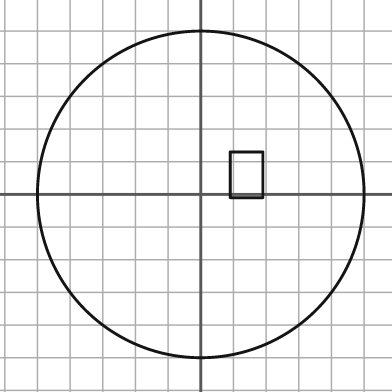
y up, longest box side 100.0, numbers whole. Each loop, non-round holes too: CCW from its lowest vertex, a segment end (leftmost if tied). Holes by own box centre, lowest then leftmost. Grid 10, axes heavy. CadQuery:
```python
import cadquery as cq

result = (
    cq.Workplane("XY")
    .moveTo(0.0, 0.0)
    .circle(50.0)
    .moveTo(9.0, -1.0)
    .lineTo(19.0, -1.0)
    .lineTo(19.0, 13.0)
    .lineTo(9.0, 13.0)
    .close()
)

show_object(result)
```